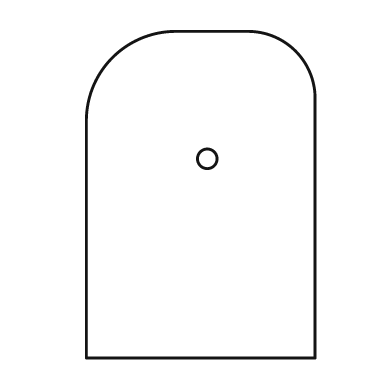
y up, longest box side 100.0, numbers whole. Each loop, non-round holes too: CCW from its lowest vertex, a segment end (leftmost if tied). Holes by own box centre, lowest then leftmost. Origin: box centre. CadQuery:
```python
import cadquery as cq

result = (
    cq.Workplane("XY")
    .moveTo(-35.0, -50.0)
    .lineTo(35.0, -50.0)
    .lineTo(35.0, 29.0)
    .threePointArc((29.0, 44.0), (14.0, 50.0))
    .lineTo(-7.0, 50.0)
    .threePointArc((-27.0, 42.0), (-35.0, 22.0))
    .close()
    .moveTo(2.0, 11.0)
    .circle(3.0)
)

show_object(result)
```